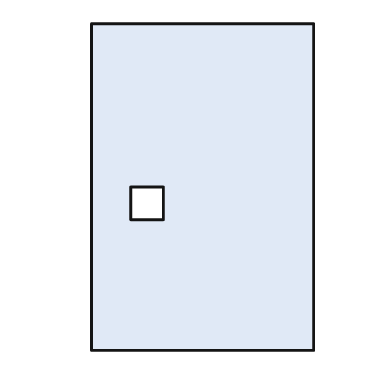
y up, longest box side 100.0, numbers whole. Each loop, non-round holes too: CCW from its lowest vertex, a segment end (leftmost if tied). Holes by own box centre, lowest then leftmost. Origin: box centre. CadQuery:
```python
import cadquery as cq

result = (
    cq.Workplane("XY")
    .moveTo(-34.0, -50.0)
    .lineTo(34.0, -50.0)
    .lineTo(34.0, 50.0)
    .lineTo(-34.0, 50.0)
    .close()
    .moveTo(-22.0, -10.0)
    .lineTo(-12.0, -10.0)
    .lineTo(-12.0, 0.0)
    .lineTo(-22.0, 0.0)
    .close()
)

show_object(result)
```